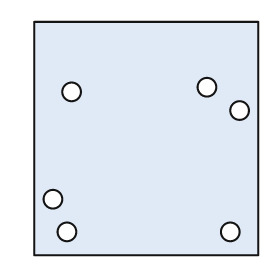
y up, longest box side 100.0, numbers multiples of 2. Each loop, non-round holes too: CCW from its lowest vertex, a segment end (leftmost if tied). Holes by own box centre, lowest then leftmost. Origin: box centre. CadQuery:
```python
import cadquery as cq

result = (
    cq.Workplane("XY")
    .moveTo(-48.0, -50.0)
    .lineTo(48.0, -50.0)
    .lineTo(48.0, 50.0)
    .lineTo(-48.0, 50.0)
    .close()
    .moveTo(-34.0, -40.0)
    .circle(4.0)
    .moveTo(36.0, -40.0)
    .circle(4.0)
    .moveTo(-40.0, -26.0)
    .circle(4.0)
    .moveTo(40.0, 12.0)
    .circle(4.0)
    .moveTo(-32.0, 20.0)
    .circle(4.0)
    .moveTo(26.0, 22.0)
    .circle(4.0)
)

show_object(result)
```